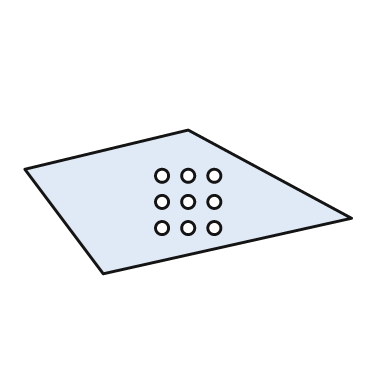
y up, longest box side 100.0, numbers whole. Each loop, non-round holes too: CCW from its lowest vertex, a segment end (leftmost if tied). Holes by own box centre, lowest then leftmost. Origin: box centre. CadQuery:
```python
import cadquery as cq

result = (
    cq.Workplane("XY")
    .moveTo(-26.0, -22.0)
    .lineTo(50.0, -5.0)
    .lineTo(0.0, 22.0)
    .lineTo(-50.0, 10.0)
    .close()
    .moveTo(-8.0, -8.0)
    .circle(2.0)
    .moveTo(0.0, -8.0)
    .circle(2.0)
    .moveTo(8.0, -8.0)
    .circle(2.0)
    .moveTo(-8.0, 0.0)
    .circle(2.0)
    .moveTo(0.0, 0.0)
    .circle(2.0)
    .moveTo(8.0, 0.0)
    .circle(2.0)
    .moveTo(-8.0, 8.0)
    .circle(2.0)
    .moveTo(0.0, 8.0)
    .circle(2.0)
    .moveTo(8.0, 8.0)
    .circle(2.0)
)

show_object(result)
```